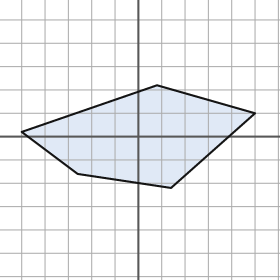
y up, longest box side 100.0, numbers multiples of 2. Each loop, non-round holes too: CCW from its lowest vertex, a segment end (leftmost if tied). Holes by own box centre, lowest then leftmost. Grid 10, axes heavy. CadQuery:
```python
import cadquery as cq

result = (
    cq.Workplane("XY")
    .moveTo(14.0, -22.0)
    .lineTo(50.0, 10.0)
    .lineTo(8.0, 22.0)
    .lineTo(-50.0, 2.0)
    .lineTo(-26.0, -16.0)
    .close()
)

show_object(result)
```